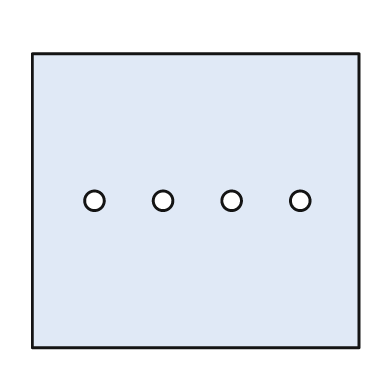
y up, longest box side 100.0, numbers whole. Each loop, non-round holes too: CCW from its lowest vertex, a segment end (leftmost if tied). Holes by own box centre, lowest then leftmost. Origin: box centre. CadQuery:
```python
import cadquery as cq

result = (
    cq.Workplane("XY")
    .moveTo(-50.0, -45.0)
    .lineTo(50.0, -45.0)
    .lineTo(50.0, 45.0)
    .lineTo(-50.0, 45.0)
    .close()
    .moveTo(-31.0, 0.0)
    .circle(3.0)
    .moveTo(-10.0, 0.0)
    .circle(3.0)
    .moveTo(11.0, 0.0)
    .circle(3.0)
    .moveTo(32.0, 0.0)
    .circle(3.0)
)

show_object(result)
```